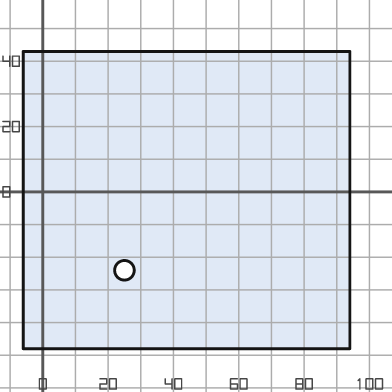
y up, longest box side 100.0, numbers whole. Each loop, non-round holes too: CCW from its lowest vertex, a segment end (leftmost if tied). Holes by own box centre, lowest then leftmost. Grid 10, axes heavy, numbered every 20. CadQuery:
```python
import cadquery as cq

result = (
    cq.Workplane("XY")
    .moveTo(-6.0, -48.0)
    .lineTo(94.0, -48.0)
    .lineTo(94.0, 43.0)
    .lineTo(-6.0, 43.0)
    .close()
    .moveTo(25.0, -24.0)
    .circle(3.0)
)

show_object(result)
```